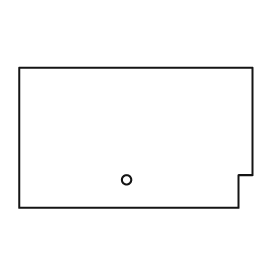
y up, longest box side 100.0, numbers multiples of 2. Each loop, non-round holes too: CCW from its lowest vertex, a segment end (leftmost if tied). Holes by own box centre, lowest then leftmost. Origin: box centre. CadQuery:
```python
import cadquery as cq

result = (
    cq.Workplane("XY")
    .moveTo(-50.0, -30.0)
    .lineTo(44.0, -30.0)
    .lineTo(44.0, -16.0)
    .lineTo(50.0, -16.0)
    .lineTo(50.0, 30.0)
    .lineTo(-50.0, 30.0)
    .close()
    .moveTo(-4.0, -18.0)
    .circle(2.0)
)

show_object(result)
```